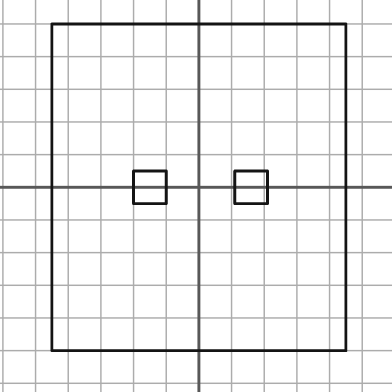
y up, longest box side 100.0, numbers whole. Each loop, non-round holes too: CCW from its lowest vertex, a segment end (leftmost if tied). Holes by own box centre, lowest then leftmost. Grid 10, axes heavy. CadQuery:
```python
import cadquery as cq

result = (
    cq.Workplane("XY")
    .moveTo(-45.0, -50.0)
    .lineTo(45.0, -50.0)
    .lineTo(45.0, 50.0)
    .lineTo(-45.0, 50.0)
    .close()
    .moveTo(-20.0, -5.0)
    .lineTo(-10.0, -5.0)
    .lineTo(-10.0, 5.0)
    .lineTo(-20.0, 5.0)
    .close()
    .moveTo(11.0, -5.0)
    .lineTo(21.0, -5.0)
    .lineTo(21.0, 5.0)
    .lineTo(11.0, 5.0)
    .close()
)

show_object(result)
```